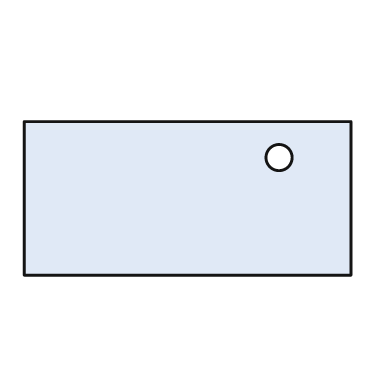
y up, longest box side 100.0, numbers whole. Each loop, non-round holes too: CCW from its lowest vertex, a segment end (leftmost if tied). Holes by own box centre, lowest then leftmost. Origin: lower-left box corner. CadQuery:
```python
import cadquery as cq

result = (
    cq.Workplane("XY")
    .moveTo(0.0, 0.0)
    .lineTo(100.0, 0.0)
    .lineTo(100.0, 47.0)
    .lineTo(0.0, 47.0)
    .close()
    .moveTo(78.0, 36.0)
    .circle(4.0)
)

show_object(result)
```